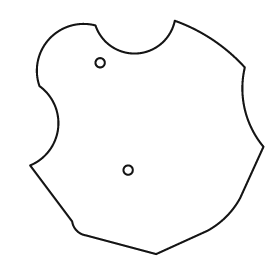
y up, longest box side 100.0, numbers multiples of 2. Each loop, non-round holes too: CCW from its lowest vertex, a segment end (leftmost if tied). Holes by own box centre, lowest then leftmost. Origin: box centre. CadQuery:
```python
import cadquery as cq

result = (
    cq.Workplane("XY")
    .moveTo(4.0, -50.0)
    .lineTo(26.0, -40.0)
    .threePointArc((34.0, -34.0), (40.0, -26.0))
    .lineTo(50.0, -4.0)
    .threePointArc((42.0, 12.0), (42.0, 30.0))
    .threePointArc((28.0, 42.0), (12.0, 50.0))
    .threePointArc((-4.0, 36.0), (-22.0, 48.0))
    .threePointArc((-42.0, 42.0), (-46.0, 22.0))
    .threePointArc((-38.0, 4.0), (-50.0, -12.0))
    .lineTo(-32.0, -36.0)
    .threePointArc((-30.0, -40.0), (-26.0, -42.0))
    .close()
    .moveTo(-8.0, -14.0)
    .circle(2.0)
    .moveTo(-20.0, 32.0)
    .circle(2.0)
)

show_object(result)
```